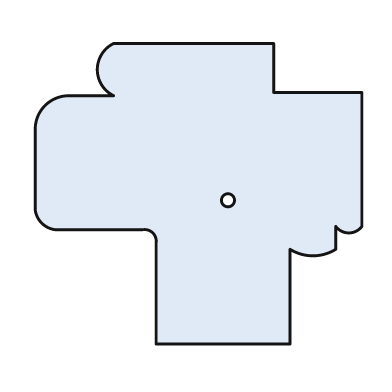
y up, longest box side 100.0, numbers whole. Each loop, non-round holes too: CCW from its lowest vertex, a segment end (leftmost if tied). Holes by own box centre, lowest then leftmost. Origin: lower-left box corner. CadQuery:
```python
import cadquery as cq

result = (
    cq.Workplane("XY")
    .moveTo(37.0, 0.0)
    .lineTo(78.0, 0.0)
    .lineTo(78.0, 29.0)
    .threePointArc((85.0, 27.0), (92.0, 29.0))
    .lineTo(92.0, 36.0)
    .threePointArc((96.0, 34.0), (100.0, 36.0))
    .lineTo(100.0, 77.0)
    .lineTo(73.0, 77.0)
    .lineTo(73.0, 92.0)
    .lineTo(24.0, 92.0)
    .threePointArc((19.0, 84.0), (24.0, 76.0))
    .lineTo(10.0, 76.0)
    .threePointArc((3.0, 73.0), (0.0, 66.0))
    .lineTo(0.0, 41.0)
    .threePointArc((2.0, 37.0), (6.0, 35.0))
    .lineTo(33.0, 35.0)
    .threePointArc((36.0, 34.0), (37.0, 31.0))
    .close()
    .moveTo(59.0, 44.0)
    .circle(2.0)
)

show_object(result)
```